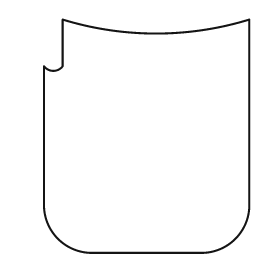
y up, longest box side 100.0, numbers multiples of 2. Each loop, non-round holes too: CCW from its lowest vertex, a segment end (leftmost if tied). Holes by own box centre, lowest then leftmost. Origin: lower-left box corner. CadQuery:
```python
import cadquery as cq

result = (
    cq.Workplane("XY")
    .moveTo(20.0, 0.0)
    .lineTo(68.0, 0.0)
    .threePointArc((82.0, 6.0), (88.0, 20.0))
    .lineTo(88.0, 100.0)
    .threePointArc((48.0, 94.0), (8.0, 100.0))
    .lineTo(8.0, 80.0)
    .threePointArc((4.0, 78.0), (0.0, 80.0))
    .lineTo(0.0, 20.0)
    .threePointArc((6.0, 6.0), (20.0, 0.0))
    .close()
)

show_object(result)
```